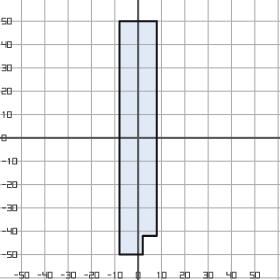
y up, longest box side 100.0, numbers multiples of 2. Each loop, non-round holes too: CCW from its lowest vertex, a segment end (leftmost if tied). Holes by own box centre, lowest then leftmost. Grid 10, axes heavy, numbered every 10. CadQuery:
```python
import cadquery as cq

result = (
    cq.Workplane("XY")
    .moveTo(-8.0, -50.0)
    .lineTo(2.0, -50.0)
    .lineTo(2.0, -42.0)
    .lineTo(8.0, -42.0)
    .lineTo(8.0, 50.0)
    .lineTo(-8.0, 50.0)
    .close()
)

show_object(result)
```